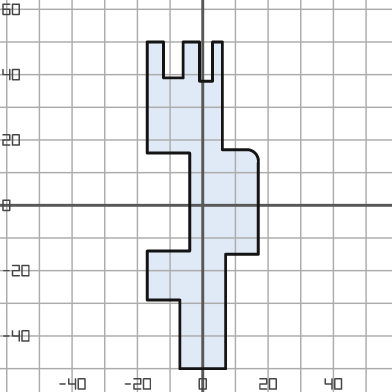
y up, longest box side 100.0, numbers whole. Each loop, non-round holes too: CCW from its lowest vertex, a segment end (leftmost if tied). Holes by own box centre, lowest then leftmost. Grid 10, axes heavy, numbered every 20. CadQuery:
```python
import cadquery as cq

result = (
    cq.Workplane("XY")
    .moveTo(-7.0, -50.0)
    .lineTo(7.0, -50.0)
    .lineTo(7.0, -15.0)
    .lineTo(17.0, -15.0)
    .lineTo(17.0, 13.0)
    .threePointArc((16.0, 16.0), (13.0, 17.0))
    .lineTo(6.0, 17.0)
    .lineTo(6.0, 50.0)
    .lineTo(3.0, 50.0)
    .lineTo(3.0, 38.0)
    .lineTo(-1.0, 38.0)
    .lineTo(-1.0, 50.0)
    .lineTo(-6.0, 50.0)
    .lineTo(-6.0, 39.0)
    .lineTo(-12.0, 39.0)
    .lineTo(-12.0, 50.0)
    .lineTo(-17.0, 50.0)
    .lineTo(-17.0, 16.0)
    .lineTo(-4.0, 16.0)
    .lineTo(-4.0, -14.0)
    .lineTo(-17.0, -14.0)
    .lineTo(-17.0, -29.0)
    .lineTo(-7.0, -29.0)
    .close()
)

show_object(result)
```